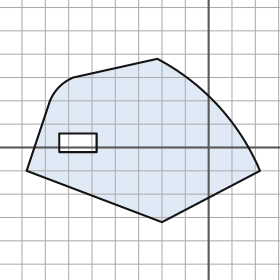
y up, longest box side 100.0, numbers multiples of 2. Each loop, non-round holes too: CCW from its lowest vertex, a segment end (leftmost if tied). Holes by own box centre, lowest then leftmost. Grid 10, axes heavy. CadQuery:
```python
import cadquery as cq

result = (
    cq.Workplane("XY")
    .moveTo(-20.0, -32.0)
    .lineTo(22.0, -10.0)
    .threePointArc((4.0, 18.0), (-22.0, 38.0))
    .lineTo(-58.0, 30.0)
    .threePointArc((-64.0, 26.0), (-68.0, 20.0))
    .lineTo(-78.0, -10.0)
    .close()
    .moveTo(-64.0, -2.0)
    .lineTo(-48.0, -2.0)
    .lineTo(-48.0, 6.0)
    .lineTo(-64.0, 6.0)
    .close()
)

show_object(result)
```